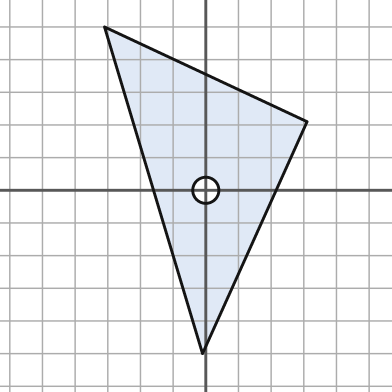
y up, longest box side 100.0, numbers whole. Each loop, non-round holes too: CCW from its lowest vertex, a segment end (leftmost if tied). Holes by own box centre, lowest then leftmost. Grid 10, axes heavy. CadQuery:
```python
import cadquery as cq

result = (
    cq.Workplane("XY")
    .moveTo(-1.0, -50.0)
    .lineTo(31.0, 21.0)
    .lineTo(-31.0, 50.0)
    .close()
    .moveTo(0.0, 0.0)
    .circle(4.0)
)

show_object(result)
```